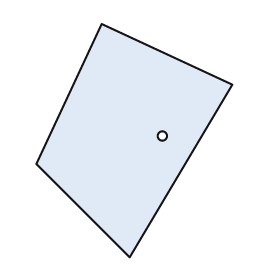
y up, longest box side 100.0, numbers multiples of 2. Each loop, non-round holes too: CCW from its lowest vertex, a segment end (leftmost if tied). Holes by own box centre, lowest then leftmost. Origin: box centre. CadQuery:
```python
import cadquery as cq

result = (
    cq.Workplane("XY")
    .moveTo(-2.0, -50.0)
    .lineTo(42.0, 24.0)
    .lineTo(-14.0, 50.0)
    .lineTo(-42.0, -10.0)
    .close()
    .moveTo(12.0, 2.0)
    .circle(2.0)
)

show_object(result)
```